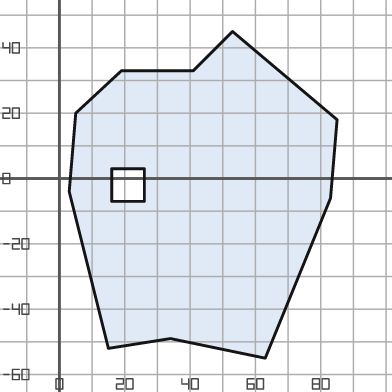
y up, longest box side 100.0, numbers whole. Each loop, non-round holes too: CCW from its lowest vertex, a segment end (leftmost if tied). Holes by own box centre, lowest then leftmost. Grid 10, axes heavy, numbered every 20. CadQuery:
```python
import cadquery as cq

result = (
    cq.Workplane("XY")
    .moveTo(63.0, -55.0)
    .lineTo(83.0, -6.0)
    .lineTo(85.0, 18.0)
    .lineTo(53.0, 45.0)
    .lineTo(41.0, 33.0)
    .lineTo(19.0, 33.0)
    .lineTo(5.0, 20.0)
    .lineTo(3.0, -4.0)
    .lineTo(15.0, -52.0)
    .lineTo(34.0, -49.0)
    .close()
    .moveTo(16.0, -7.0)
    .lineTo(26.0, -7.0)
    .lineTo(26.0, 3.0)
    .lineTo(16.0, 3.0)
    .close()
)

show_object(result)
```